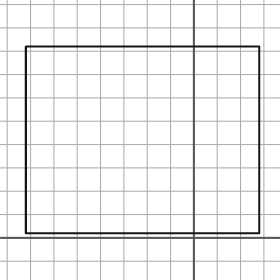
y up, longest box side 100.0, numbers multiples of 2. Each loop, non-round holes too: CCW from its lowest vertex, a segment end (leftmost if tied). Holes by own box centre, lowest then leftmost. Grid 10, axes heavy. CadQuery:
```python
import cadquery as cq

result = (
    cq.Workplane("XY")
    .moveTo(-72.0, 2.0)
    .lineTo(28.0, 2.0)
    .lineTo(28.0, 82.0)
    .lineTo(-72.0, 82.0)
    .close()
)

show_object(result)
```